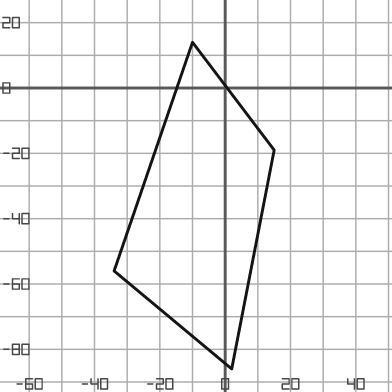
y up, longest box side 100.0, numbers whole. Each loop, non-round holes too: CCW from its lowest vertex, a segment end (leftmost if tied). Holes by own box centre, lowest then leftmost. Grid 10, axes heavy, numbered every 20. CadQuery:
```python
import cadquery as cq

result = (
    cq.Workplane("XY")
    .moveTo(2.0, -86.0)
    .lineTo(15.0, -19.0)
    .lineTo(-10.0, 14.0)
    .lineTo(-34.0, -56.0)
    .close()
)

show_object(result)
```